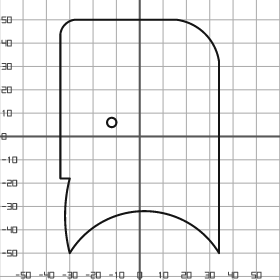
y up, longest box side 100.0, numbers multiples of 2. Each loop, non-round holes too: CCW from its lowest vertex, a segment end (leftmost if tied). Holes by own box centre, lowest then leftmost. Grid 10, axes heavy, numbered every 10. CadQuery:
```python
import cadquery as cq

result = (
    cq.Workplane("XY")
    .moveTo(-30.0, -50.0)
    .threePointArc((2.0, -32.0), (34.0, -50.0))
    .lineTo(34.0, 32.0)
    .threePointArc((28.0, 44.0), (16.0, 50.0))
    .lineTo(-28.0, 50.0)
    .threePointArc((-32.0, 48.0), (-34.0, 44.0))
    .lineTo(-34.0, -18.0)
    .lineTo(-30.0, -18.0)
    .threePointArc((-32.0, -34.0), (-30.0, -50.0))
    .close()
    .moveTo(-12.0, 6.0)
    .circle(2.0)
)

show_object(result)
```